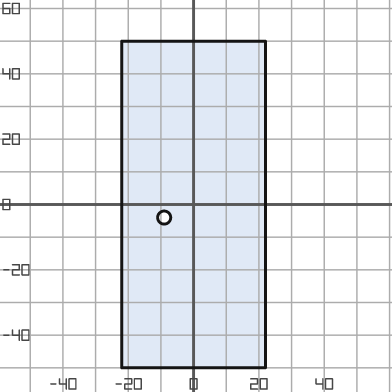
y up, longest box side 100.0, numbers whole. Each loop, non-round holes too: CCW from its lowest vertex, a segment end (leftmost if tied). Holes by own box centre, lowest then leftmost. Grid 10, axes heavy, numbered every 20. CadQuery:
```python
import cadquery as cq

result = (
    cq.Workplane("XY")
    .moveTo(-22.0, -50.0)
    .lineTo(22.0, -50.0)
    .lineTo(22.0, 50.0)
    .lineTo(-22.0, 50.0)
    .close()
    .moveTo(-9.0, -4.0)
    .circle(2.0)
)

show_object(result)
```